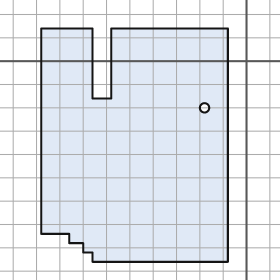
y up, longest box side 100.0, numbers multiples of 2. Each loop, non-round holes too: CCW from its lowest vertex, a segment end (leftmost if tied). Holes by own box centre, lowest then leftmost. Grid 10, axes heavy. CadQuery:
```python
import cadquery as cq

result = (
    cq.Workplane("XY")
    .moveTo(-66.0, -86.0)
    .lineTo(-8.0, -86.0)
    .lineTo(-8.0, 14.0)
    .lineTo(-58.0, 14.0)
    .lineTo(-58.0, -16.0)
    .lineTo(-66.0, -16.0)
    .lineTo(-66.0, 14.0)
    .lineTo(-88.0, 14.0)
    .lineTo(-88.0, -74.0)
    .lineTo(-76.0, -74.0)
    .lineTo(-76.0, -78.0)
    .lineTo(-70.0, -78.0)
    .lineTo(-70.0, -82.0)
    .lineTo(-66.0, -82.0)
    .close()
    .moveTo(-18.0, -20.0)
    .circle(2.0)
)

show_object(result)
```